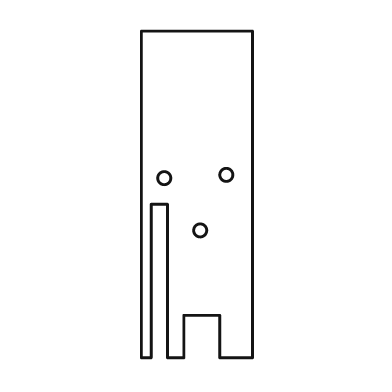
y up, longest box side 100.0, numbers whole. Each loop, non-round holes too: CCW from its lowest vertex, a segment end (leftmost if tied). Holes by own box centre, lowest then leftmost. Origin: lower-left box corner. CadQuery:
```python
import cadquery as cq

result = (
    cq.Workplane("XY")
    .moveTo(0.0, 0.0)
    .lineTo(3.0, 0.0)
    .lineTo(3.0, 47.0)
    .lineTo(8.0, 47.0)
    .lineTo(8.0, 0.0)
    .lineTo(13.0, 0.0)
    .lineTo(13.0, 13.0)
    .lineTo(24.0, 13.0)
    .lineTo(24.0, 0.0)
    .lineTo(34.0, 0.0)
    .lineTo(34.0, 100.0)
    .lineTo(0.0, 100.0)
    .close()
    .moveTo(18.0, 39.0)
    .circle(2.0)
    .moveTo(7.0, 55.0)
    .circle(2.0)
    .moveTo(26.0, 56.0)
    .circle(2.0)
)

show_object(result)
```